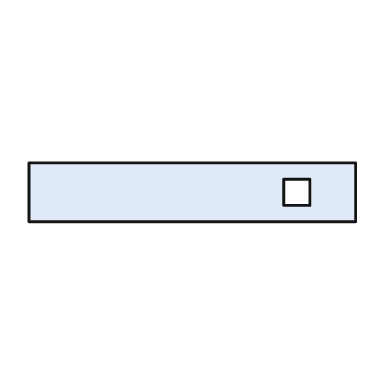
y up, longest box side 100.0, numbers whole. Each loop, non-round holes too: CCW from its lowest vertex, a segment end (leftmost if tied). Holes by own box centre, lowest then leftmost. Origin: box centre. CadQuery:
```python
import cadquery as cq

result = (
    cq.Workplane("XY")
    .moveTo(-50.0, -9.0)
    .lineTo(50.0, -9.0)
    .lineTo(50.0, 9.0)
    .lineTo(-50.0, 9.0)
    .close()
    .moveTo(28.0, -4.0)
    .lineTo(36.0, -4.0)
    .lineTo(36.0, 4.0)
    .lineTo(28.0, 4.0)
    .close()
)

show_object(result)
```